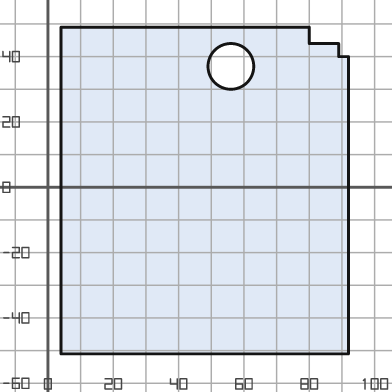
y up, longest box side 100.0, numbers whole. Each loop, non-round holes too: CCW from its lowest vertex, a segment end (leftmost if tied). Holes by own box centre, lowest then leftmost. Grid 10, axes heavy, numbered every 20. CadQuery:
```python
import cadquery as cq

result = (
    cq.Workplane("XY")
    .moveTo(4.0, -51.0)
    .lineTo(92.0, -51.0)
    .lineTo(92.0, 40.0)
    .lineTo(89.0, 40.0)
    .lineTo(89.0, 44.0)
    .lineTo(80.0, 44.0)
    .lineTo(80.0, 49.0)
    .lineTo(4.0, 49.0)
    .close()
    .moveTo(56.0, 37.0)
    .circle(7.0)
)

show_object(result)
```